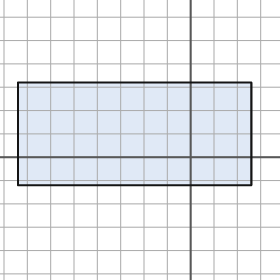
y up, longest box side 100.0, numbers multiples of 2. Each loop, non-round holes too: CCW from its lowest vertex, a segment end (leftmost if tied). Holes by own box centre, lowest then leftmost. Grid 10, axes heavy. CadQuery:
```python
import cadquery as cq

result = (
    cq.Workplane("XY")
    .moveTo(-74.0, -12.0)
    .lineTo(26.0, -12.0)
    .lineTo(26.0, 32.0)
    .lineTo(-74.0, 32.0)
    .close()
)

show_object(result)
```